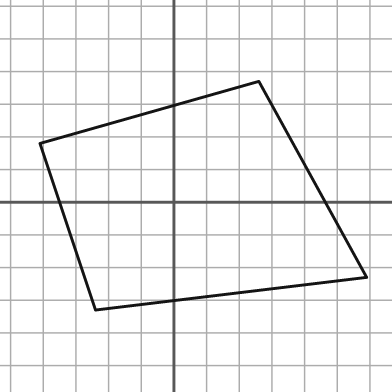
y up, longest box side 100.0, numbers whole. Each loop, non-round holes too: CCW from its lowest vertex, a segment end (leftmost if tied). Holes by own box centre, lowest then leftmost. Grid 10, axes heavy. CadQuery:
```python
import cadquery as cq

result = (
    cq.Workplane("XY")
    .moveTo(-24.0, -33.0)
    .lineTo(59.0, -23.0)
    .lineTo(26.0, 37.0)
    .lineTo(-41.0, 18.0)
    .close()
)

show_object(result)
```